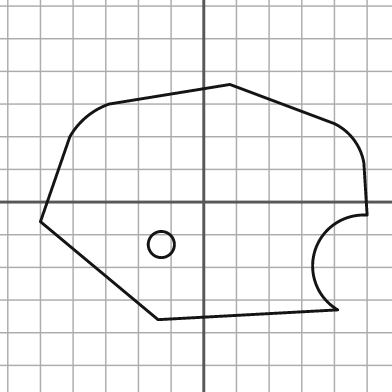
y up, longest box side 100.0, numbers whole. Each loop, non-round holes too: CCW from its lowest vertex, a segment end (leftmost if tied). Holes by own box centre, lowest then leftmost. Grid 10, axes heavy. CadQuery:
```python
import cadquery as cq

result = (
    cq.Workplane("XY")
    .moveTo(-14.0, -36.0)
    .lineTo(41.0, -33.0)
    .threePointArc((34.0, -15.0), (50.0, -4.0))
    .lineTo(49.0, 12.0)
    .threePointArc((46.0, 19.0), (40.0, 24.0))
    .lineTo(8.0, 36.0)
    .lineTo(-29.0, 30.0)
    .threePointArc((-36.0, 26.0), (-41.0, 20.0))
    .lineTo(-50.0, -6.0)
    .close()
    .moveTo(-13.0, -13.0)
    .circle(4.0)
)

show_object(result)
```